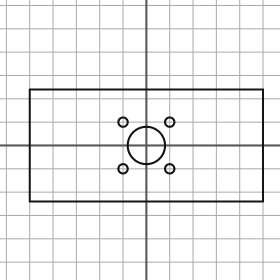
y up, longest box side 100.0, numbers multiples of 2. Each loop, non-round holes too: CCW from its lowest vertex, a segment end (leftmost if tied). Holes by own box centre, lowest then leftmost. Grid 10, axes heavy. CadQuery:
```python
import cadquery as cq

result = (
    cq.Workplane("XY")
    .moveTo(-50.0, -24.0)
    .lineTo(50.0, -24.0)
    .lineTo(50.0, 24.0)
    .lineTo(-50.0, 24.0)
    .close()
    .moveTo(-10.0, -10.0)
    .circle(2.0)
    .moveTo(10.0, -10.0)
    .circle(2.0)
    .moveTo(0.0, 0.0)
    .circle(8.0)
    .moveTo(-10.0, 10.0)
    .circle(2.0)
    .moveTo(10.0, 10.0)
    .circle(2.0)
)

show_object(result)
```